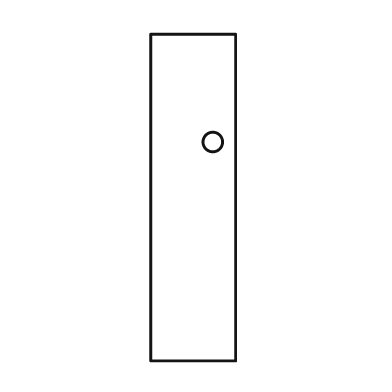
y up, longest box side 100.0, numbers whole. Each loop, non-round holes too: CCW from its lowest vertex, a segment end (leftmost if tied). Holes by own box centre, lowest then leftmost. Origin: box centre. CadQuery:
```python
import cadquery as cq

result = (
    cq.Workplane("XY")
    .moveTo(-13.0, -50.0)
    .lineTo(13.0, -50.0)
    .lineTo(13.0, 50.0)
    .lineTo(-13.0, 50.0)
    .close()
    .moveTo(6.0, 17.0)
    .circle(3.0)
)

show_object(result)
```